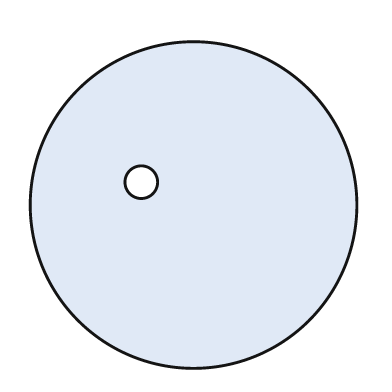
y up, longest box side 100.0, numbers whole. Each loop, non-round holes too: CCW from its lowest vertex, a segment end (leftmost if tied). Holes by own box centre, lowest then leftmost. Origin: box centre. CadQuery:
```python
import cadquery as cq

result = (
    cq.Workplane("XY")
    .moveTo(0.0, 0.0)
    .circle(50.0)
    .moveTo(-16.0, 7.0)
    .circle(5.0)
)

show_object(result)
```